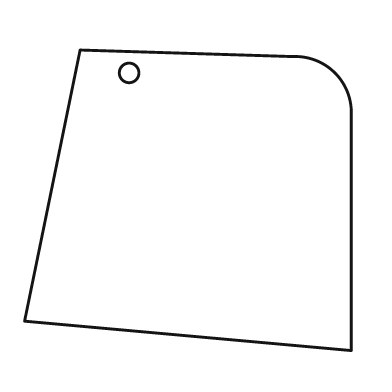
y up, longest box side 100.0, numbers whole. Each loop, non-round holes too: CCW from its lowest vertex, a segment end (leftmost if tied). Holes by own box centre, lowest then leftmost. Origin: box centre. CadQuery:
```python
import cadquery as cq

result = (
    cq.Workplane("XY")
    .moveTo(50.0, -46.0)
    .lineTo(50.0, 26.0)
    .threePointArc((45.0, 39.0), (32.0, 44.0))
    .lineTo(-33.0, 46.0)
    .lineTo(-50.0, -37.0)
    .close()
    .moveTo(-18.0, 39.0)
    .circle(3.0)
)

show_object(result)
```